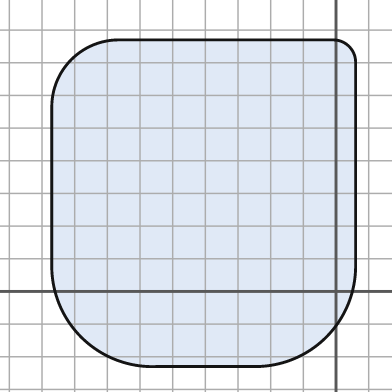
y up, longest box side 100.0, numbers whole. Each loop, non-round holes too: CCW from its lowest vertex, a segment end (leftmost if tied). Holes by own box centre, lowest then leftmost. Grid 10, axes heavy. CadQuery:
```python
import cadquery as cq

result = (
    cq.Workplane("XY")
    .moveTo(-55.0, -23.0)
    .lineTo(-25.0, -23.0)
    .threePointArc((-3.0, -14.0), (6.0, 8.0))
    .lineTo(6.0, 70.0)
    .threePointArc((4.0, 75.0), (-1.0, 77.0))
    .lineTo(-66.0, 77.0)
    .threePointArc((-81.0, 71.0), (-87.0, 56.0))
    .lineTo(-87.0, 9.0)
    .threePointArc((-78.0, -14.0), (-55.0, -23.0))
    .close()
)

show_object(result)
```